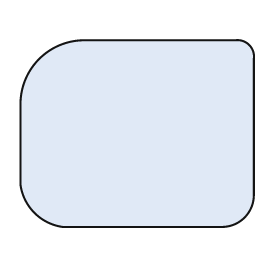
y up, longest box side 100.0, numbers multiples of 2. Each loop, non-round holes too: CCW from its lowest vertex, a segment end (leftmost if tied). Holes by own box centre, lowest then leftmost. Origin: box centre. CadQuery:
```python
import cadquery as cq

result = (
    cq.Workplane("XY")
    .moveTo(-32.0, -40.0)
    .lineTo(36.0, -40.0)
    .threePointArc((46.0, -36.0), (50.0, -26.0))
    .lineTo(50.0, 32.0)
    .threePointArc((48.0, 38.0), (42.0, 40.0))
    .lineTo(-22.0, 40.0)
    .threePointArc((-42.0, 32.0), (-50.0, 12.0))
    .lineTo(-50.0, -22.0)
    .threePointArc((-44.0, -34.0), (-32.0, -40.0))
    .close()
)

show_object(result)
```